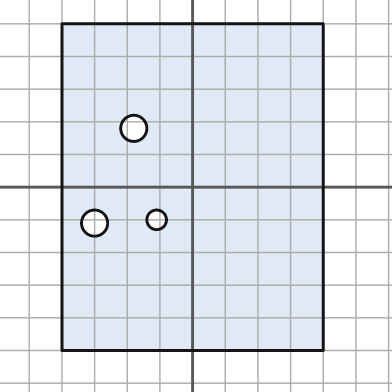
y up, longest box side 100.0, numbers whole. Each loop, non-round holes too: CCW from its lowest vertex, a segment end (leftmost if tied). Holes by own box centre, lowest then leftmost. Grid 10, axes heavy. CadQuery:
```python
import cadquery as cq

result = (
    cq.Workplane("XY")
    .moveTo(-40.0, -50.0)
    .lineTo(40.0, -50.0)
    .lineTo(40.0, 50.0)
    .lineTo(-40.0, 50.0)
    .close()
    .moveTo(-30.0, -11.0)
    .circle(4.0)
    .moveTo(-11.0, -10.0)
    .circle(3.0)
    .moveTo(-18.0, 18.0)
    .circle(4.0)
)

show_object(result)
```